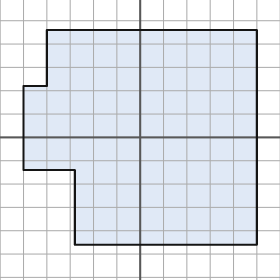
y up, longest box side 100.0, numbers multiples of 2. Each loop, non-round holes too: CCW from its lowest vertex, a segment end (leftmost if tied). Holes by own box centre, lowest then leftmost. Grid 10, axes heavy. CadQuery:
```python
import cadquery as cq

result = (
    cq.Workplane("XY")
    .moveTo(-28.0, -46.0)
    .lineTo(50.0, -46.0)
    .lineTo(50.0, 46.0)
    .lineTo(-40.0, 46.0)
    .lineTo(-40.0, 22.0)
    .lineTo(-50.0, 22.0)
    .lineTo(-50.0, -14.0)
    .lineTo(-28.0, -14.0)
    .close()
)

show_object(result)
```